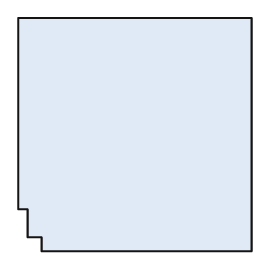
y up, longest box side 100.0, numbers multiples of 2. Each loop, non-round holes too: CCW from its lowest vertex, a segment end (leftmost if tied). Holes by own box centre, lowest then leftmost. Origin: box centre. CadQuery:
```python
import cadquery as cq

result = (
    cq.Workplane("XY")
    .moveTo(-40.0, -50.0)
    .lineTo(50.0, -50.0)
    .lineTo(50.0, 50.0)
    .lineTo(-50.0, 50.0)
    .lineTo(-50.0, -32.0)
    .lineTo(-46.0, -32.0)
    .lineTo(-46.0, -44.0)
    .lineTo(-40.0, -44.0)
    .close()
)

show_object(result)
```